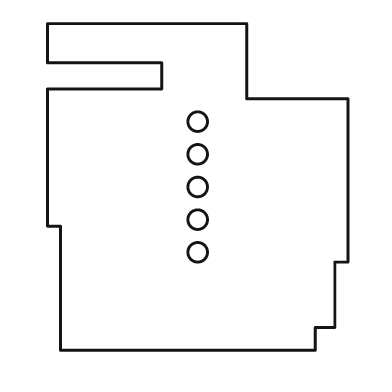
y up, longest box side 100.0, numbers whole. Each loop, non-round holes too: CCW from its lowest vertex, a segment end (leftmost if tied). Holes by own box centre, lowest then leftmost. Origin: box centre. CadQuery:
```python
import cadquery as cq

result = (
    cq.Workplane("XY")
    .moveTo(-42.0, -50.0)
    .lineTo(36.0, -50.0)
    .lineTo(36.0, -43.0)
    .lineTo(42.0, -43.0)
    .lineTo(42.0, -23.0)
    .lineTo(46.0, -23.0)
    .lineTo(46.0, 27.0)
    .lineTo(15.0, 27.0)
    .lineTo(15.0, 50.0)
    .lineTo(-46.0, 50.0)
    .lineTo(-46.0, 38.0)
    .lineTo(-11.0, 38.0)
    .lineTo(-11.0, 30.0)
    .lineTo(-46.0, 30.0)
    .lineTo(-46.0, -12.0)
    .lineTo(-42.0, -12.0)
    .close()
    .moveTo(0.0, -20.0)
    .circle(3.0)
    .moveTo(0.0, -10.0)
    .circle(3.0)
    .moveTo(0.0, 0.0)
    .circle(3.0)
    .moveTo(0.0, 10.0)
    .circle(3.0)
    .moveTo(0.0, 20.0)
    .circle(3.0)
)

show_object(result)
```